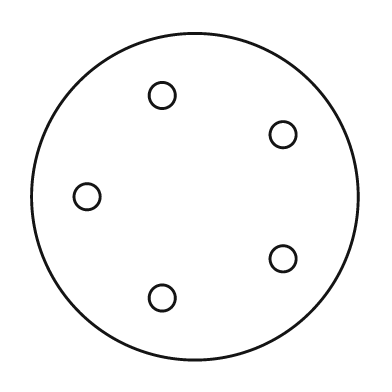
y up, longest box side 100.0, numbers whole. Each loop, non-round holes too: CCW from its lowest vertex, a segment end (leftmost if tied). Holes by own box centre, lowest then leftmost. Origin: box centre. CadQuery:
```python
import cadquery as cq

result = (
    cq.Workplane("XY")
    .moveTo(0.0, 0.0)
    .circle(50.0)
    .moveTo(-10.0, -31.0)
    .circle(4.0)
    .moveTo(27.0, -19.0)
    .circle(4.0)
    .moveTo(-33.0, 0.0)
    .circle(4.0)
    .moveTo(27.0, 19.0)
    .circle(4.0)
    .moveTo(-10.0, 31.0)
    .circle(4.0)
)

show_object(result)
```